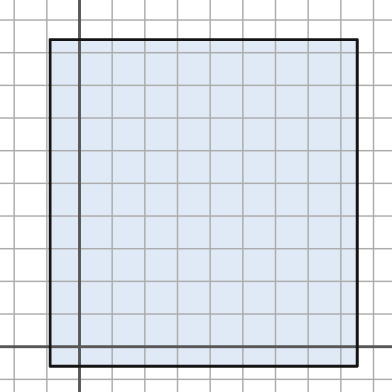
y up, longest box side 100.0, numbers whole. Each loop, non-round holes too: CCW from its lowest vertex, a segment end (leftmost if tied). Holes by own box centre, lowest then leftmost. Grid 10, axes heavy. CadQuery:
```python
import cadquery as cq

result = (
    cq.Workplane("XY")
    .moveTo(-9.0, -6.0)
    .lineTo(85.0, -6.0)
    .lineTo(85.0, 94.0)
    .lineTo(-9.0, 94.0)
    .close()
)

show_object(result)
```